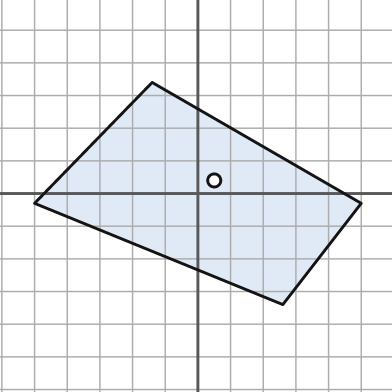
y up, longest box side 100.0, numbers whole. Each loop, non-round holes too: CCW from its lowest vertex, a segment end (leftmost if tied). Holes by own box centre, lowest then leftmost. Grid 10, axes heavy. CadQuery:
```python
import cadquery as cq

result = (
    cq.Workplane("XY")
    .moveTo(26.0, -34.0)
    .lineTo(50.0, -3.0)
    .lineTo(-14.0, 34.0)
    .lineTo(-50.0, -3.0)
    .close()
    .moveTo(5.0, 4.0)
    .circle(2.0)
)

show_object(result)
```